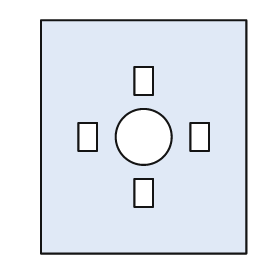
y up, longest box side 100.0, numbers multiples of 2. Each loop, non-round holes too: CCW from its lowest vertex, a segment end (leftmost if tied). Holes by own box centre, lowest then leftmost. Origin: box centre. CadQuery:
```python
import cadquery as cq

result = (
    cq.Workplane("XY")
    .moveTo(-44.0, -50.0)
    .lineTo(44.0, -50.0)
    .lineTo(44.0, 50.0)
    .lineTo(-44.0, 50.0)
    .close()
    .moveTo(-4.0, -30.0)
    .lineTo(4.0, -30.0)
    .lineTo(4.0, -18.0)
    .lineTo(-4.0, -18.0)
    .close()
    .moveTo(-28.0, -6.0)
    .lineTo(-20.0, -6.0)
    .lineTo(-20.0, 6.0)
    .lineTo(-28.0, 6.0)
    .close()
    .moveTo(0.0, 0.0)
    .circle(12.0)
    .moveTo(20.0, -6.0)
    .lineTo(28.0, -6.0)
    .lineTo(28.0, 6.0)
    .lineTo(20.0, 6.0)
    .close()
    .moveTo(-4.0, 18.0)
    .lineTo(4.0, 18.0)
    .lineTo(4.0, 30.0)
    .lineTo(-4.0, 30.0)
    .close()
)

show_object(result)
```